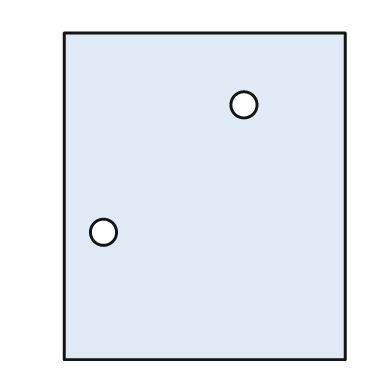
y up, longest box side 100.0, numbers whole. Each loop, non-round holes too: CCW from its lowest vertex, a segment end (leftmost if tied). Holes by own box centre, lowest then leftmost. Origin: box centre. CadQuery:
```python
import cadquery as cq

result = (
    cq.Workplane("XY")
    .moveTo(-43.0, -50.0)
    .lineTo(43.0, -50.0)
    .lineTo(43.0, 50.0)
    .lineTo(-43.0, 50.0)
    .close()
    .moveTo(-31.0, -11.0)
    .circle(4.0)
    .moveTo(12.0, 28.0)
    .circle(4.0)
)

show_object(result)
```